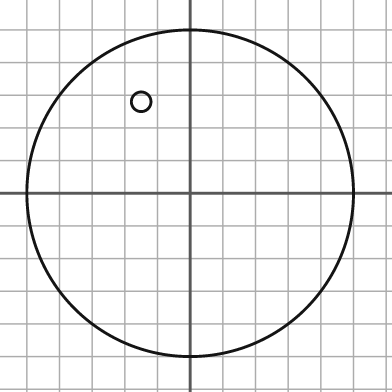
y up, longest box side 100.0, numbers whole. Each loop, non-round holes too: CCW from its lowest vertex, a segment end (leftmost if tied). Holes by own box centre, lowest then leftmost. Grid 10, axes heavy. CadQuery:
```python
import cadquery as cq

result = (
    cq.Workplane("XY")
    .moveTo(0.0, 0.0)
    .circle(50.0)
    .moveTo(-15.0, 28.0)
    .circle(3.0)
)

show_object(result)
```